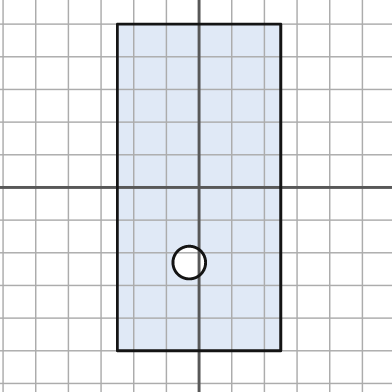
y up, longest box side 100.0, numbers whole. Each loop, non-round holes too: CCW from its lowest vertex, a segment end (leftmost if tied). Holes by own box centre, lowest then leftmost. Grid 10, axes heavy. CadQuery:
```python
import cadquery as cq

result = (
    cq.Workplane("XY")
    .moveTo(-25.0, -50.0)
    .lineTo(25.0, -50.0)
    .lineTo(25.0, 50.0)
    .lineTo(-25.0, 50.0)
    .close()
    .moveTo(-3.0, -23.0)
    .circle(5.0)
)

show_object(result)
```